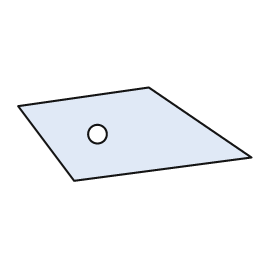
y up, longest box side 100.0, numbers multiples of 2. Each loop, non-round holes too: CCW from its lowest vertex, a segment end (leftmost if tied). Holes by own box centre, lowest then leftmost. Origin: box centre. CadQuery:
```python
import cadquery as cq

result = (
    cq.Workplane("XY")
    .moveTo(-26.0, -20.0)
    .lineTo(50.0, -10.0)
    .lineTo(6.0, 20.0)
    .lineTo(-50.0, 12.0)
    .close()
    .moveTo(-16.0, 0.0)
    .circle(4.0)
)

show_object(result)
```